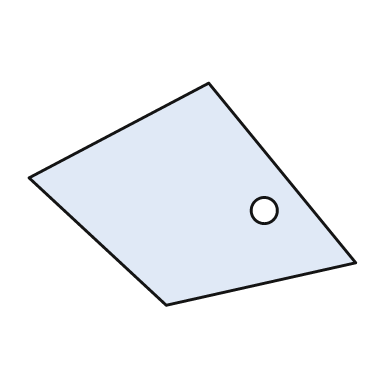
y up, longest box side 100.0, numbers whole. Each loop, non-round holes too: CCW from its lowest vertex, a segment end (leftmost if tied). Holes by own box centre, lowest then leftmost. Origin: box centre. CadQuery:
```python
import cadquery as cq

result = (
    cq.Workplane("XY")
    .moveTo(-8.0, -34.0)
    .lineTo(50.0, -21.0)
    .lineTo(5.0, 34.0)
    .lineTo(-50.0, 5.0)
    .close()
    .moveTo(22.0, -5.0)
    .circle(4.0)
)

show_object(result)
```